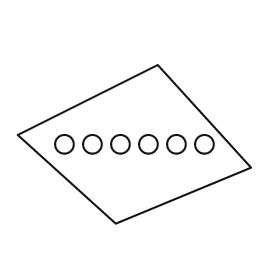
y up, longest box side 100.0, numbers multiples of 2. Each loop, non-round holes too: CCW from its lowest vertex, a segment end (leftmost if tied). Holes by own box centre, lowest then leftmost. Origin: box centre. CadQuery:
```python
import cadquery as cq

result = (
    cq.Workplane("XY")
    .moveTo(-8.0, -34.0)
    .lineTo(50.0, -10.0)
    .lineTo(10.0, 34.0)
    .lineTo(-50.0, 4.0)
    .close()
    .moveTo(-30.0, 0.0)
    .circle(4.0)
    .moveTo(-18.0, 0.0)
    .circle(4.0)
    .moveTo(-6.0, 0.0)
    .circle(4.0)
    .moveTo(6.0, 0.0)
    .circle(4.0)
    .moveTo(18.0, 0.0)
    .circle(4.0)
    .moveTo(30.0, 0.0)
    .circle(4.0)
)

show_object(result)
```